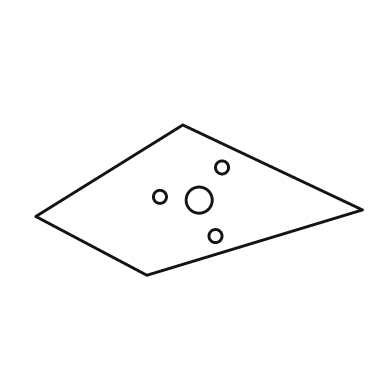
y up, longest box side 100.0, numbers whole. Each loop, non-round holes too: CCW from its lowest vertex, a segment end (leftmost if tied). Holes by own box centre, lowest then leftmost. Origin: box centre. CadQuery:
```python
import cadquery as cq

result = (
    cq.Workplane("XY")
    .moveTo(-16.0, -23.0)
    .lineTo(50.0, -3.0)
    .lineTo(-5.0, 23.0)
    .lineTo(-50.0, -5.0)
    .close()
    .moveTo(5.0, -11.0)
    .circle(2.0)
    .moveTo(0.0, 0.0)
    .circle(4.0)
    .moveTo(-12.0, 1.0)
    .circle(2.0)
    .moveTo(7.0, 10.0)
    .circle(2.0)
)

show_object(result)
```